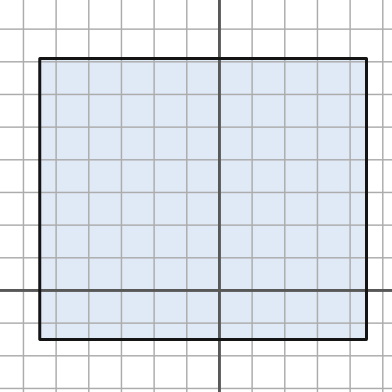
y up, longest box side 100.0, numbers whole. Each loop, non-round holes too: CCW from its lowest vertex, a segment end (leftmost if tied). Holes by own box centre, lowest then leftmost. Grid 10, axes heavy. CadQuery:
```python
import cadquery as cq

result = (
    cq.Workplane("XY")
    .moveTo(-55.0, -15.0)
    .lineTo(45.0, -15.0)
    .lineTo(45.0, 71.0)
    .lineTo(-55.0, 71.0)
    .close()
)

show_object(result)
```